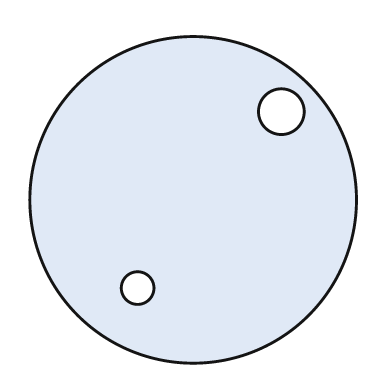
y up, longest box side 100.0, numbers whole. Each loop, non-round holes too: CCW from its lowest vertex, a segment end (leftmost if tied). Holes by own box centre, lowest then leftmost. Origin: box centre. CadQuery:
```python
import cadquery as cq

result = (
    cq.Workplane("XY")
    .moveTo(0.0, 0.0)
    .circle(50.0)
    .moveTo(-17.0, -27.0)
    .circle(5.0)
    .moveTo(27.0, 27.0)
    .circle(7.0)
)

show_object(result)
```